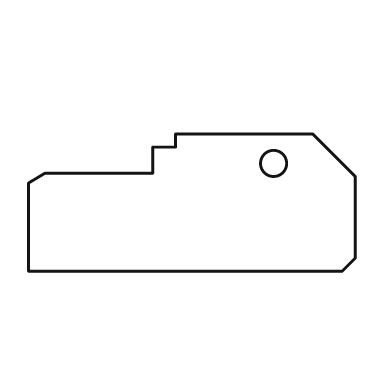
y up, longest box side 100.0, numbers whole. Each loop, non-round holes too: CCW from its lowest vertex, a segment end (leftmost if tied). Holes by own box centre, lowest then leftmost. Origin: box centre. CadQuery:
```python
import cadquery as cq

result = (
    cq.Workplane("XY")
    .moveTo(-50.0, -21.0)
    .lineTo(46.0, -21.0)
    .lineTo(50.0, -17.0)
    .lineTo(50.0, 8.0)
    .lineTo(37.0, 21.0)
    .lineTo(-5.0, 21.0)
    .lineTo(-5.0, 17.0)
    .lineTo(-12.0, 17.0)
    .lineTo(-12.0, 9.0)
    .lineTo(-45.0, 9.0)
    .lineTo(-50.0, 6.0)
    .close()
    .moveTo(25.0, 12.0)
    .circle(4.0)
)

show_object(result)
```